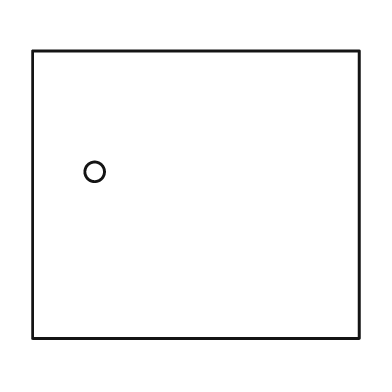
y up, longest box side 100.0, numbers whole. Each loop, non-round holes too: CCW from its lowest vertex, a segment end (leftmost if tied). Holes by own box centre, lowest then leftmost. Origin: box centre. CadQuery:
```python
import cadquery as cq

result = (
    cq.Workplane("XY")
    .moveTo(-50.0, -44.0)
    .lineTo(50.0, -44.0)
    .lineTo(50.0, 44.0)
    .lineTo(-50.0, 44.0)
    .close()
    .moveTo(-31.0, 7.0)
    .circle(3.0)
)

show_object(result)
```